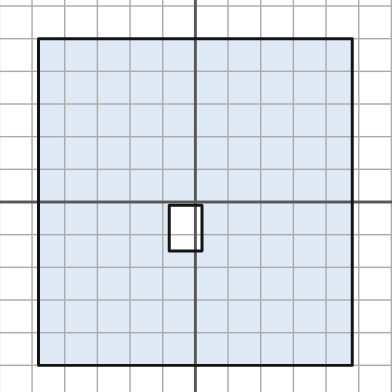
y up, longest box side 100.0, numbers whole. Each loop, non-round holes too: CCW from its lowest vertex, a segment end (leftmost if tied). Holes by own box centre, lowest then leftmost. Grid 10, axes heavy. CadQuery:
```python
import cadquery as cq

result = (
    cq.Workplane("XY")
    .moveTo(-48.0, -50.0)
    .lineTo(48.0, -50.0)
    .lineTo(48.0, 50.0)
    .lineTo(-48.0, 50.0)
    .close()
    .moveTo(-8.0, -15.0)
    .lineTo(2.0, -15.0)
    .lineTo(2.0, -1.0)
    .lineTo(-8.0, -1.0)
    .close()
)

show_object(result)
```